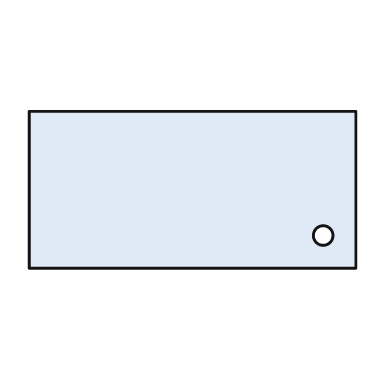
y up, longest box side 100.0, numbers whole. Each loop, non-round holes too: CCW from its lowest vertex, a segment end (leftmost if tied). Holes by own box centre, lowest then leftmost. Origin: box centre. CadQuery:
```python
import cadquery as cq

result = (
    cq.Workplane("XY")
    .moveTo(-50.0, -24.0)
    .lineTo(50.0, -24.0)
    .lineTo(50.0, 24.0)
    .lineTo(-50.0, 24.0)
    .close()
    .moveTo(40.0, -14.0)
    .circle(3.0)
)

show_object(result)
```